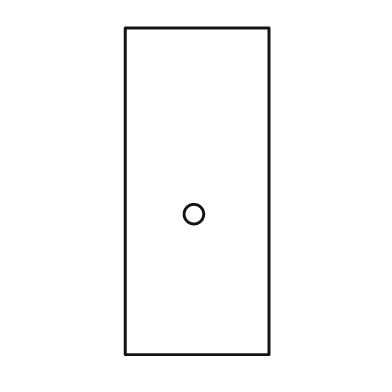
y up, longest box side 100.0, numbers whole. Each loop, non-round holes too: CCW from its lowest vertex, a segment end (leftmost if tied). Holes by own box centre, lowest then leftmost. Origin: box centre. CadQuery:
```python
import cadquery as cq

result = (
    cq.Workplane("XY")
    .moveTo(-22.0, -50.0)
    .lineTo(22.0, -50.0)
    .lineTo(22.0, 50.0)
    .lineTo(-22.0, 50.0)
    .close()
    .moveTo(-1.0, -7.0)
    .circle(3.0)
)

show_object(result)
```